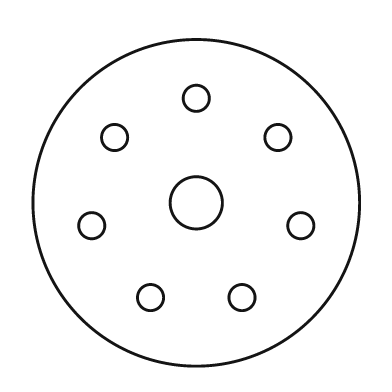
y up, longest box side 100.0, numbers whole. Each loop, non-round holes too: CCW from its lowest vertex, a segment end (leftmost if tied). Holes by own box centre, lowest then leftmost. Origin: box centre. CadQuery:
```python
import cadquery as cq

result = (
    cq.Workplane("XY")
    .moveTo(0.0, 0.0)
    .circle(50.0)
    .moveTo(-14.0, -29.0)
    .circle(4.0)
    .moveTo(14.0, -29.0)
    .circle(4.0)
    .moveTo(-32.0, -7.0)
    .circle(4.0)
    .moveTo(32.0, -7.0)
    .circle(4.0)
    .moveTo(0.0, 0.0)
    .circle(8.0)
    .moveTo(-25.0, 20.0)
    .circle(4.0)
    .moveTo(25.0, 20.0)
    .circle(4.0)
    .moveTo(0.0, 32.0)
    .circle(4.0)
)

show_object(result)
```